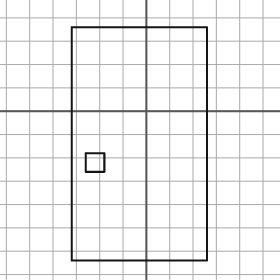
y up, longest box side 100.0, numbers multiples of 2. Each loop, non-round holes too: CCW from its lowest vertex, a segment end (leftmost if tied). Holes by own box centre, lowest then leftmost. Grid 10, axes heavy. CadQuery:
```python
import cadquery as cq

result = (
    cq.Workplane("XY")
    .moveTo(-32.0, -64.0)
    .lineTo(26.0, -64.0)
    .lineTo(26.0, 36.0)
    .lineTo(-32.0, 36.0)
    .close()
    .moveTo(-26.0, -26.0)
    .lineTo(-18.0, -26.0)
    .lineTo(-18.0, -18.0)
    .lineTo(-26.0, -18.0)
    .close()
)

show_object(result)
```